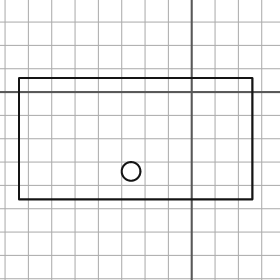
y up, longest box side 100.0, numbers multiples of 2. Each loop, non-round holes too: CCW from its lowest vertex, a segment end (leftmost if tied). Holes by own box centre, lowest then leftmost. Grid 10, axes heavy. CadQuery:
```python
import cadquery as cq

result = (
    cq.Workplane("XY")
    .moveTo(-74.0, -46.0)
    .lineTo(26.0, -46.0)
    .lineTo(26.0, 6.0)
    .lineTo(-74.0, 6.0)
    .close()
    .moveTo(-26.0, -34.0)
    .circle(4.0)
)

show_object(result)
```